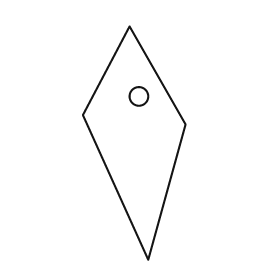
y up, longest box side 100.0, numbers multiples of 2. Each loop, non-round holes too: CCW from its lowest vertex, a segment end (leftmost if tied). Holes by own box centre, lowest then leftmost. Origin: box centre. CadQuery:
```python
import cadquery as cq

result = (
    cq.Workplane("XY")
    .moveTo(6.0, -50.0)
    .lineTo(22.0, 8.0)
    .lineTo(-2.0, 50.0)
    .lineTo(-22.0, 12.0)
    .close()
    .moveTo(2.0, 20.0)
    .circle(4.0)
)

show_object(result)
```